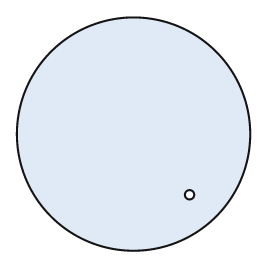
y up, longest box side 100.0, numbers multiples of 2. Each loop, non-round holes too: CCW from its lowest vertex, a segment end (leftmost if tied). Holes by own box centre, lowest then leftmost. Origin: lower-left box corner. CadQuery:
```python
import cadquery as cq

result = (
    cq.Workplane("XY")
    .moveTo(50.0, 50.0)
    .circle(50.0)
    .moveTo(74.0, 24.0)
    .circle(2.0)
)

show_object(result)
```